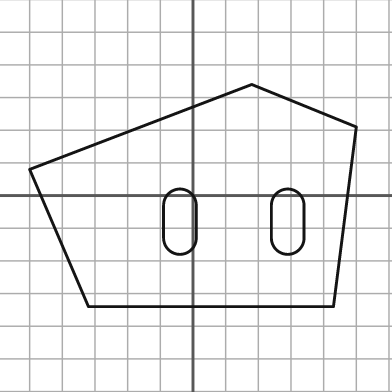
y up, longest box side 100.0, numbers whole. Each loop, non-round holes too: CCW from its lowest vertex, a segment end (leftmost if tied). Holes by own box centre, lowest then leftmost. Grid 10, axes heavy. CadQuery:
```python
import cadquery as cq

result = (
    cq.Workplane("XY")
    .moveTo(-32.0, -34.0)
    .lineTo(43.0, -34.0)
    .lineTo(50.0, 21.0)
    .lineTo(18.0, 34.0)
    .lineTo(-50.0, 8.0)
    .close()
    .moveTo(-9.0, -13.0)
    .threePointArc((-4.0, -18.0), (1.0, -13.0))
    .lineTo(1.0, -3.0)
    .threePointArc((-4.0, 2.0), (-9.0, -3.0))
    .close()
    .moveTo(24.0, -13.0)
    .threePointArc((29.0, -18.0), (34.0, -13.0))
    .lineTo(34.0, -3.0)
    .threePointArc((29.0, 2.0), (24.0, -3.0))
    .close()
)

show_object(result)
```